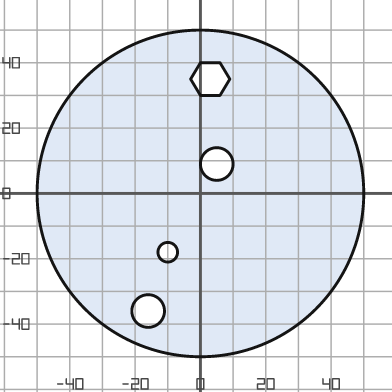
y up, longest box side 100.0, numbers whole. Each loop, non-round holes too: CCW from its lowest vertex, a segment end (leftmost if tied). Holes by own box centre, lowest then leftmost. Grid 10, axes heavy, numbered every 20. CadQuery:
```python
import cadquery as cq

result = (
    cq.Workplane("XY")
    .moveTo(0.0, 0.0)
    .circle(50.0)
    .moveTo(-16.0, -36.0)
    .circle(5.0)
    .moveTo(-10.0, -18.0)
    .circle(3.0)
    .moveTo(5.0, 9.0)
    .circle(5.0)
    .moveTo(0.0, 30.0)
    .lineTo(6.0, 30.0)
    .lineTo(9.0, 35.0)
    .lineTo(6.0, 40.0)
    .lineTo(0.0, 40.0)
    .lineTo(-3.0, 35.0)
    .close()
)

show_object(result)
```